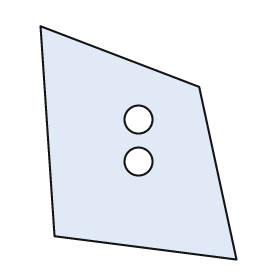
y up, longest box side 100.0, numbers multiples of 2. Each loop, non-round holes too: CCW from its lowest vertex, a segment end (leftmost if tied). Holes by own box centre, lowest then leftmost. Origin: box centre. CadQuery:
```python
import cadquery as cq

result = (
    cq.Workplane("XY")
    .moveTo(42.0, -50.0)
    .lineTo(26.0, 24.0)
    .lineTo(-42.0, 50.0)
    .lineTo(-36.0, -40.0)
    .close()
    .moveTo(0.0, -8.0)
    .circle(6.0)
    .moveTo(0.0, 10.0)
    .circle(6.0)
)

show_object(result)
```